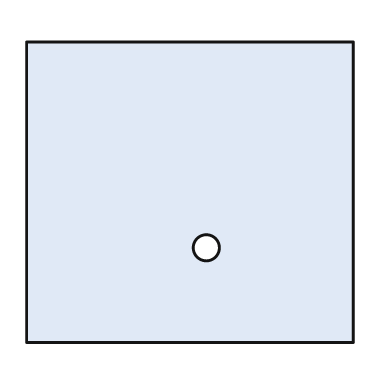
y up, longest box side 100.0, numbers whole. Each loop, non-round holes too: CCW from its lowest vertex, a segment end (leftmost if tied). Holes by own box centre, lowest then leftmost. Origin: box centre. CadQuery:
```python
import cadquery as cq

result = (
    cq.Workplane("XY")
    .moveTo(-50.0, -46.0)
    .lineTo(50.0, -46.0)
    .lineTo(50.0, 46.0)
    .lineTo(-50.0, 46.0)
    .close()
    .moveTo(5.0, -17.0)
    .circle(4.0)
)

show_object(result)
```